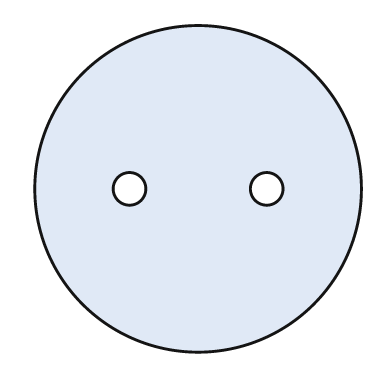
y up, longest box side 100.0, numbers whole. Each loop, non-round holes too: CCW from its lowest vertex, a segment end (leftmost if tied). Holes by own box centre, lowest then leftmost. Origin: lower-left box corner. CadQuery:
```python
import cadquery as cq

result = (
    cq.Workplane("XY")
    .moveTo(50.0, 50.0)
    .circle(50.0)
    .moveTo(29.0, 50.0)
    .circle(5.0)
    .moveTo(71.0, 50.0)
    .circle(5.0)
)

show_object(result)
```